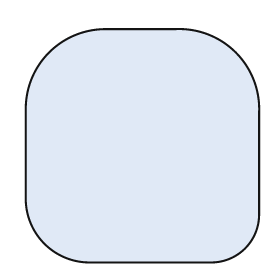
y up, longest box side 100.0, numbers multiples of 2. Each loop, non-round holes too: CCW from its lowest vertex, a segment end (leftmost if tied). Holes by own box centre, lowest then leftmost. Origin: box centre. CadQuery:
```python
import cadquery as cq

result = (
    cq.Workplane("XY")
    .moveTo(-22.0, -50.0)
    .lineTo(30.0, -50.0)
    .threePointArc((44.0, -44.0), (50.0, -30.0))
    .lineTo(50.0, 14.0)
    .threePointArc((40.0, 40.0), (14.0, 50.0))
    .lineTo(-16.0, 50.0)
    .threePointArc((-40.0, 40.0), (-50.0, 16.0))
    .lineTo(-50.0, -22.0)
    .threePointArc((-42.0, -42.0), (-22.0, -50.0))
    .close()
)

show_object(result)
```